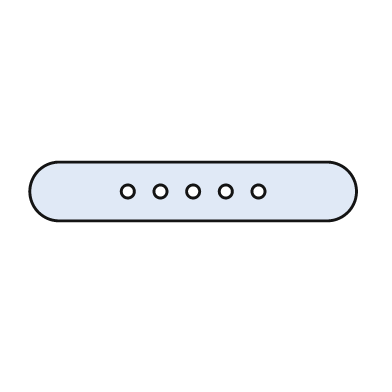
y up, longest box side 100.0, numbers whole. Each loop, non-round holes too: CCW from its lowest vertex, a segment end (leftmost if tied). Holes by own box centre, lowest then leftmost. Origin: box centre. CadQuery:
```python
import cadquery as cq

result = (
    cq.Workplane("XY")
    .moveTo(-41.0, -9.0)
    .lineTo(41.0, -9.0)
    .threePointArc((50.0, 0.0), (41.0, 9.0))
    .lineTo(-41.0, 9.0)
    .threePointArc((-50.0, 0.0), (-41.0, -9.0))
    .close()
    .moveTo(-20.0, 0.0)
    .circle(2.0)
    .moveTo(-10.0, 0.0)
    .circle(2.0)
    .moveTo(0.0, 0.0)
    .circle(2.0)
    .moveTo(10.0, 0.0)
    .circle(2.0)
    .moveTo(20.0, 0.0)
    .circle(2.0)
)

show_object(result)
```